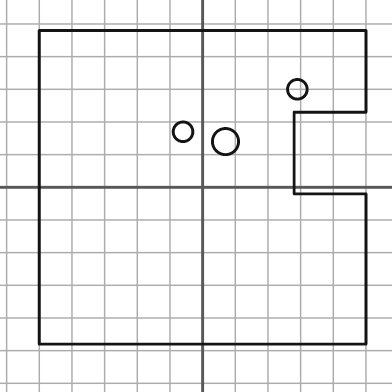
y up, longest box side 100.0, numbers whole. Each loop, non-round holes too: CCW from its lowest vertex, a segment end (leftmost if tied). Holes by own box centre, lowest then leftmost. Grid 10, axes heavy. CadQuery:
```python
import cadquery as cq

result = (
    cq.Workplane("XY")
    .moveTo(-50.0, -48.0)
    .lineTo(50.0, -48.0)
    .lineTo(50.0, -2.0)
    .lineTo(28.0, -2.0)
    .lineTo(28.0, 23.0)
    .lineTo(50.0, 23.0)
    .lineTo(50.0, 48.0)
    .lineTo(-50.0, 48.0)
    .close()
    .moveTo(7.0, 14.0)
    .circle(4.0)
    .moveTo(-6.0, 17.0)
    .circle(3.0)
    .moveTo(29.0, 30.0)
    .circle(3.0)
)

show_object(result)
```